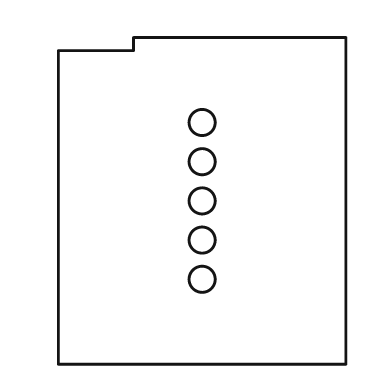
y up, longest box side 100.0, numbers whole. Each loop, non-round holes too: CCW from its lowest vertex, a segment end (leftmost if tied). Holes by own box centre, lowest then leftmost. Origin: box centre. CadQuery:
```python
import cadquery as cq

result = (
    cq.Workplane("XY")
    .moveTo(-44.0, -50.0)
    .lineTo(44.0, -50.0)
    .lineTo(44.0, 50.0)
    .lineTo(-21.0, 50.0)
    .lineTo(-21.0, 46.0)
    .lineTo(-44.0, 46.0)
    .close()
    .moveTo(0.0, -24.0)
    .circle(4.0)
    .moveTo(0.0, -12.0)
    .circle(4.0)
    .moveTo(0.0, 0.0)
    .circle(4.0)
    .moveTo(0.0, 12.0)
    .circle(4.0)
    .moveTo(0.0, 24.0)
    .circle(4.0)
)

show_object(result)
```